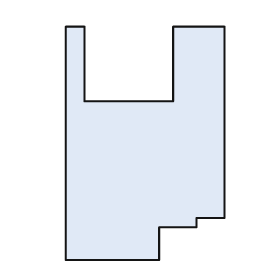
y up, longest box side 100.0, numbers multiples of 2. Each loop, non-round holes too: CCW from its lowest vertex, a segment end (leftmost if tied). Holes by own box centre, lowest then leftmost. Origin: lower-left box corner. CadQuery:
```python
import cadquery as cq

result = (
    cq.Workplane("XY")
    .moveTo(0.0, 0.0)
    .lineTo(40.0, 0.0)
    .lineTo(40.0, 14.0)
    .lineTo(56.0, 14.0)
    .lineTo(56.0, 18.0)
    .lineTo(68.0, 18.0)
    .lineTo(68.0, 100.0)
    .lineTo(46.0, 100.0)
    .lineTo(46.0, 68.0)
    .lineTo(8.0, 68.0)
    .lineTo(8.0, 100.0)
    .lineTo(0.0, 100.0)
    .close()
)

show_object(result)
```